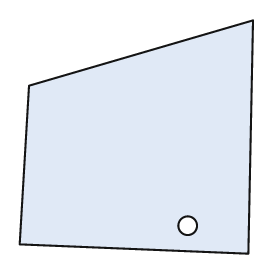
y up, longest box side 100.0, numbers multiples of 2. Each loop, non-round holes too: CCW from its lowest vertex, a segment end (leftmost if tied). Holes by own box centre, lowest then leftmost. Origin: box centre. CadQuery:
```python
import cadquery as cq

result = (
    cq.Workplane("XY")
    .moveTo(48.0, -50.0)
    .lineTo(50.0, 50.0)
    .lineTo(-46.0, 22.0)
    .lineTo(-50.0, -46.0)
    .close()
    .moveTo(22.0, -38.0)
    .circle(4.0)
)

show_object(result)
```